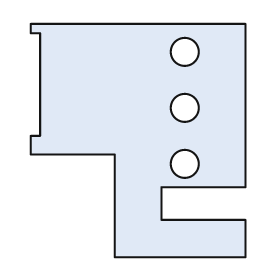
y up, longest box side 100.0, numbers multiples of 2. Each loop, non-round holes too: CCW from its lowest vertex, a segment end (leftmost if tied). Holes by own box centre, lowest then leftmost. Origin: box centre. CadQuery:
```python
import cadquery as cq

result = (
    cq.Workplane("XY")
    .moveTo(-10.0, -50.0)
    .lineTo(46.0, -50.0)
    .lineTo(46.0, -34.0)
    .lineTo(10.0, -34.0)
    .lineTo(10.0, -20.0)
    .lineTo(46.0, -20.0)
    .lineTo(46.0, 50.0)
    .lineTo(-46.0, 50.0)
    .lineTo(-46.0, 46.0)
    .lineTo(-42.0, 46.0)
    .lineTo(-42.0, 2.0)
    .lineTo(-46.0, 2.0)
    .lineTo(-46.0, -6.0)
    .lineTo(-10.0, -6.0)
    .close()
    .moveTo(20.0, -10.0)
    .circle(6.0)
    .moveTo(20.0, 14.0)
    .circle(6.0)
    .moveTo(20.0, 38.0)
    .circle(6.0)
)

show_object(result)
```